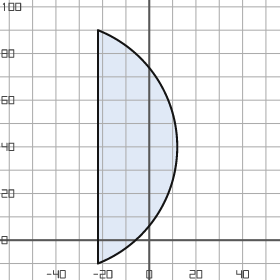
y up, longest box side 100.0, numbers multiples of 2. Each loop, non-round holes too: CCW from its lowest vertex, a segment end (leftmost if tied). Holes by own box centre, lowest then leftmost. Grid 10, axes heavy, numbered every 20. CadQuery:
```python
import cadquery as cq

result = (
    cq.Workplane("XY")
    .moveTo(-22.0, -10.0)
    .threePointArc((12.0, 40.0), (-22.0, 90.0))
    .close()
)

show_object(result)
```